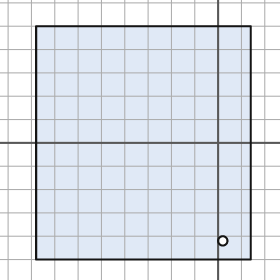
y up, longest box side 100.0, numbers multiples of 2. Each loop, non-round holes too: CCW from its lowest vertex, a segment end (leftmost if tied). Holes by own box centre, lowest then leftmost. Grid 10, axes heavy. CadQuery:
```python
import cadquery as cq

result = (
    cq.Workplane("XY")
    .moveTo(-78.0, -50.0)
    .lineTo(14.0, -50.0)
    .lineTo(14.0, 50.0)
    .lineTo(-78.0, 50.0)
    .close()
    .moveTo(2.0, -42.0)
    .circle(2.0)
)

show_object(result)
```